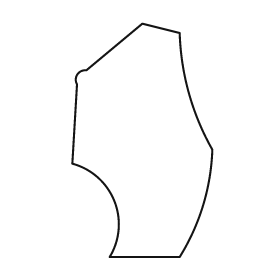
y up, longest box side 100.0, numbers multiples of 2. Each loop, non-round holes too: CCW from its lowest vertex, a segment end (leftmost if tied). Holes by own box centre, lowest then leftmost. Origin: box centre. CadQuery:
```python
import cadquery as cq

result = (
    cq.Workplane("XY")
    .moveTo(-14.0, -50.0)
    .lineTo(16.0, -50.0)
    .threePointArc((26.0, -28.0), (30.0, -4.0))
    .threePointArc((20.0, 20.0), (16.0, 46.0))
    .lineTo(0.0, 50.0)
    .lineTo(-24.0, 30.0)
    .threePointArc((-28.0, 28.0), (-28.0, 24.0))
    .lineTo(-30.0, -10.0)
    .threePointArc((-12.0, -26.0), (-14.0, -50.0))
    .close()
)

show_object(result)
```